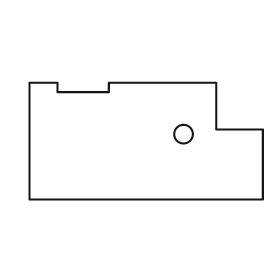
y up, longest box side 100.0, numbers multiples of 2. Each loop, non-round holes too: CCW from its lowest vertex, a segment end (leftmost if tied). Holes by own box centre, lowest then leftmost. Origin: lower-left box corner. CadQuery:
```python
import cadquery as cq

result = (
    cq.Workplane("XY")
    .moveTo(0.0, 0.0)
    .lineTo(100.0, 0.0)
    .lineTo(100.0, 30.0)
    .lineTo(80.0, 30.0)
    .lineTo(80.0, 50.0)
    .lineTo(34.0, 50.0)
    .lineTo(34.0, 46.0)
    .lineTo(12.0, 46.0)
    .lineTo(12.0, 50.0)
    .lineTo(0.0, 50.0)
    .close()
    .moveTo(66.0, 28.0)
    .circle(4.0)
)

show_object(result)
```